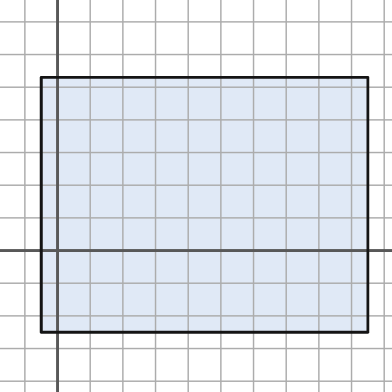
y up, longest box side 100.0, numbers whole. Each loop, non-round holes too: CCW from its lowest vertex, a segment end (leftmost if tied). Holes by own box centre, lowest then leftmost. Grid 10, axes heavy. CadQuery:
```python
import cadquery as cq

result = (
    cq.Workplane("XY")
    .moveTo(-5.0, -25.0)
    .lineTo(95.0, -25.0)
    .lineTo(95.0, 53.0)
    .lineTo(-5.0, 53.0)
    .close()
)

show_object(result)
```